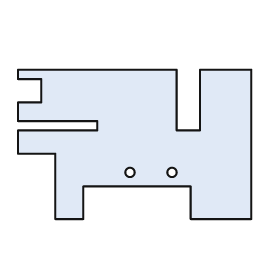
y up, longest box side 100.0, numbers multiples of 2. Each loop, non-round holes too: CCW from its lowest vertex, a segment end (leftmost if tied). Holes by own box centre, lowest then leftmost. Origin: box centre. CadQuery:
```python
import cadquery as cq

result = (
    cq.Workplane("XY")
    .moveTo(-34.0, -32.0)
    .lineTo(-22.0, -32.0)
    .lineTo(-22.0, -18.0)
    .lineTo(24.0, -18.0)
    .lineTo(24.0, -32.0)
    .lineTo(50.0, -32.0)
    .lineTo(50.0, 32.0)
    .lineTo(28.0, 32.0)
    .lineTo(28.0, 6.0)
    .lineTo(18.0, 6.0)
    .lineTo(18.0, 32.0)
    .lineTo(-50.0, 32.0)
    .lineTo(-50.0, 28.0)
    .lineTo(-40.0, 28.0)
    .lineTo(-40.0, 18.0)
    .lineTo(-50.0, 18.0)
    .lineTo(-50.0, 10.0)
    .lineTo(-16.0, 10.0)
    .lineTo(-16.0, 6.0)
    .lineTo(-50.0, 6.0)
    .lineTo(-50.0, -4.0)
    .lineTo(-34.0, -4.0)
    .close()
    .moveTo(-2.0, -12.0)
    .circle(2.0)
    .moveTo(16.0, -12.0)
    .circle(2.0)
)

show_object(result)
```